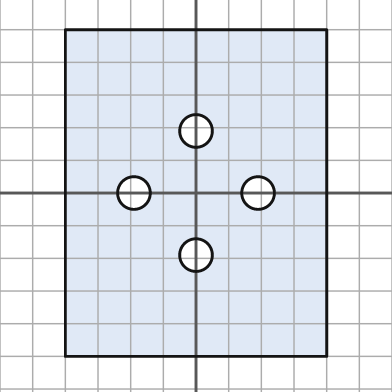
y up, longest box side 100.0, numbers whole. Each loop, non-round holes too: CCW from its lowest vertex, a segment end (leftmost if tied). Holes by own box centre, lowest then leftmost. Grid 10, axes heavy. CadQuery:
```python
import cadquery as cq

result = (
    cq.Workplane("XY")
    .moveTo(-40.0, -50.0)
    .lineTo(40.0, -50.0)
    .lineTo(40.0, 50.0)
    .lineTo(-40.0, 50.0)
    .close()
    .moveTo(0.0, -19.0)
    .circle(5.0)
    .moveTo(-19.0, 0.0)
    .circle(5.0)
    .moveTo(19.0, 0.0)
    .circle(5.0)
    .moveTo(0.0, 19.0)
    .circle(5.0)
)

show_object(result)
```